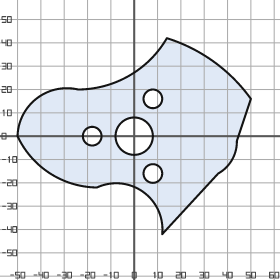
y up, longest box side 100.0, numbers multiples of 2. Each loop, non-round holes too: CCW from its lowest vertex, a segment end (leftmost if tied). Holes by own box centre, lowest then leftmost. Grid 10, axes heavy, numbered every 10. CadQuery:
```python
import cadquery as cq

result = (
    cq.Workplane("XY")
    .moveTo(12.0, -42.0)
    .lineTo(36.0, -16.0)
    .threePointArc((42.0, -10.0), (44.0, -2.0))
    .lineTo(50.0, 16.0)
    .threePointArc((34.0, 32.0), (14.0, 42.0))
    .threePointArc((-2.0, 26.0), (-24.0, 20.0))
    .threePointArc((-42.0, 16.0), (-50.0, 0.0))
    .threePointArc((-36.0, -16.0), (-16.0, -22.0))
    .threePointArc((4.0, -24.0), (12.0, -42.0))
    .close()
    .moveTo(8.0, -16.0)
    .circle(4.0)
    .moveTo(-18.0, 0.0)
    .circle(4.0)
    .moveTo(0.0, 0.0)
    .circle(8.0)
    .moveTo(8.0, 16.0)
    .circle(4.0)
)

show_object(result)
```